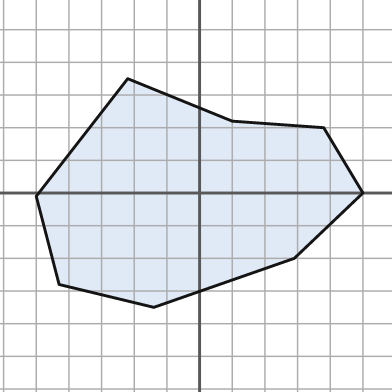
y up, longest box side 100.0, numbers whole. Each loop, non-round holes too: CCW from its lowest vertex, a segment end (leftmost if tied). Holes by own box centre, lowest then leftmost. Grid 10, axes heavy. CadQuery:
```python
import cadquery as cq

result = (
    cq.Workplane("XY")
    .moveTo(-14.0, -35.0)
    .lineTo(29.0, -20.0)
    .lineTo(50.0, 0.0)
    .lineTo(38.0, 20.0)
    .lineTo(10.0, 22.0)
    .lineTo(-22.0, 35.0)
    .lineTo(-50.0, -1.0)
    .lineTo(-43.0, -28.0)
    .close()
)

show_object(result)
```